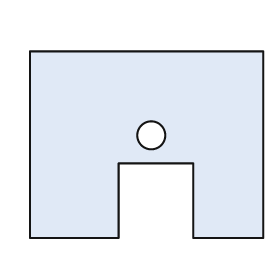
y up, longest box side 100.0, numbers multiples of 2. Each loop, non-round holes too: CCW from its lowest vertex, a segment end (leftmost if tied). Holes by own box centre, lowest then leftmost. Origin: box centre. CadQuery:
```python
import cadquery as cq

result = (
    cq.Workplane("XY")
    .moveTo(-50.0, -40.0)
    .lineTo(-12.0, -40.0)
    .lineTo(-12.0, -8.0)
    .lineTo(20.0, -8.0)
    .lineTo(20.0, -40.0)
    .lineTo(50.0, -40.0)
    .lineTo(50.0, 40.0)
    .lineTo(-50.0, 40.0)
    .close()
    .moveTo(2.0, 4.0)
    .circle(6.0)
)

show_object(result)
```